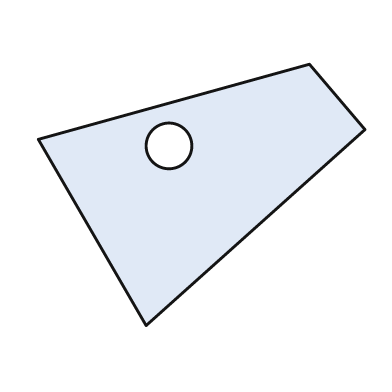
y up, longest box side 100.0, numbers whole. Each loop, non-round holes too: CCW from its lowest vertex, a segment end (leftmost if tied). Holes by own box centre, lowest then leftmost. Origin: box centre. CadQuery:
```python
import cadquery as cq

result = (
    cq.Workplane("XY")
    .moveTo(-17.0, -40.0)
    .lineTo(50.0, 20.0)
    .lineTo(33.0, 40.0)
    .lineTo(-50.0, 17.0)
    .close()
    .moveTo(-10.0, 15.0)
    .circle(7.0)
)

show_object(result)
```